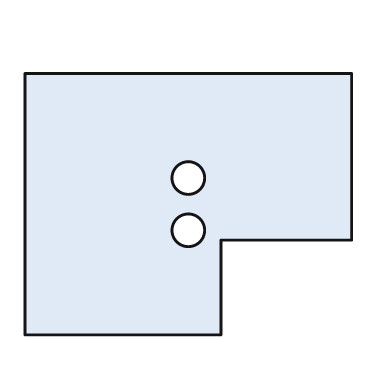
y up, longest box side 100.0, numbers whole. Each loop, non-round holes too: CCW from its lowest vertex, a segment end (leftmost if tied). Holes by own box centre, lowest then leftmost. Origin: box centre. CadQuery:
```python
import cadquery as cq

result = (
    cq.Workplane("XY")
    .moveTo(-50.0, -40.0)
    .lineTo(10.0, -40.0)
    .lineTo(10.0, -11.0)
    .lineTo(50.0, -11.0)
    .lineTo(50.0, 40.0)
    .lineTo(-50.0, 40.0)
    .close()
    .moveTo(0.0, -8.0)
    .circle(5.0)
    .moveTo(0.0, 8.0)
    .circle(5.0)
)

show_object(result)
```